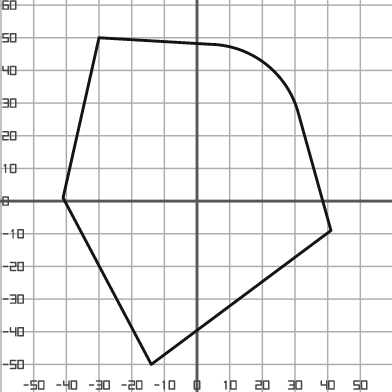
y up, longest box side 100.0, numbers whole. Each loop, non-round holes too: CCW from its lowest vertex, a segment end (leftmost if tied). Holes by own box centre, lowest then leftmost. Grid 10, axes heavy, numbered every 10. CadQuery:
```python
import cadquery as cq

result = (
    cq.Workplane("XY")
    .moveTo(-14.0, -50.0)
    .lineTo(41.0, -9.0)
    .lineTo(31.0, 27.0)
    .threePointArc((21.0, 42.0), (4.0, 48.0))
    .lineTo(-30.0, 50.0)
    .lineTo(-41.0, 1.0)
    .close()
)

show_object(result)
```